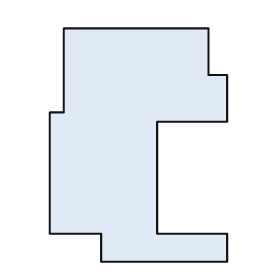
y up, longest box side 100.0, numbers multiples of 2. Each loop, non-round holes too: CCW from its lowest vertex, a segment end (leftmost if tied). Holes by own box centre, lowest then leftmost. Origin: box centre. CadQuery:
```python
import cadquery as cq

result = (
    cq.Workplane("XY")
    .moveTo(-16.0, -50.0)
    .lineTo(38.0, -50.0)
    .lineTo(38.0, -38.0)
    .lineTo(8.0, -38.0)
    .lineTo(8.0, 10.0)
    .lineTo(38.0, 10.0)
    .lineTo(38.0, 30.0)
    .lineTo(30.0, 30.0)
    .lineTo(30.0, 50.0)
    .lineTo(-32.0, 50.0)
    .lineTo(-32.0, 14.0)
    .lineTo(-38.0, 14.0)
    .lineTo(-38.0, -38.0)
    .lineTo(-16.0, -38.0)
    .close()
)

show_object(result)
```